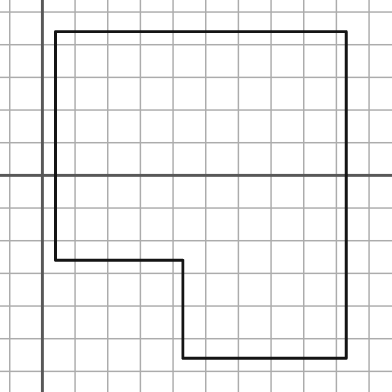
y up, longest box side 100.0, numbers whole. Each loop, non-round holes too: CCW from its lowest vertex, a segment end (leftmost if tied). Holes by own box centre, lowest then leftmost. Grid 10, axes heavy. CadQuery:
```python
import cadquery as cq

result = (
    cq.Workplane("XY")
    .moveTo(43.0, -56.0)
    .lineTo(93.0, -56.0)
    .lineTo(93.0, 44.0)
    .lineTo(4.0, 44.0)
    .lineTo(4.0, -26.0)
    .lineTo(43.0, -26.0)
    .close()
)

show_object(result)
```